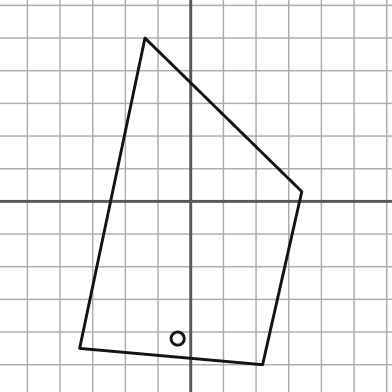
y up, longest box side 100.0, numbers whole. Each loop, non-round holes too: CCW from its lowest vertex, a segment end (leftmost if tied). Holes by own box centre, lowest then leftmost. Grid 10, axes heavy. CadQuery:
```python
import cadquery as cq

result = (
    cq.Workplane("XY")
    .moveTo(22.0, -50.0)
    .lineTo(34.0, 3.0)
    .lineTo(-14.0, 50.0)
    .lineTo(-34.0, -45.0)
    .close()
    .moveTo(-4.0, -42.0)
    .circle(2.0)
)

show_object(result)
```